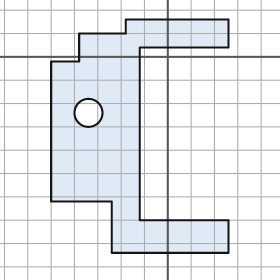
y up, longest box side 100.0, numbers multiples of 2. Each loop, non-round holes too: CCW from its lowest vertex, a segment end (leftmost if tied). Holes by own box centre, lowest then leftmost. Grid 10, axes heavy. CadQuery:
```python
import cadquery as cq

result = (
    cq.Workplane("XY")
    .moveTo(-24.0, -84.0)
    .lineTo(26.0, -84.0)
    .lineTo(26.0, -70.0)
    .lineTo(-12.0, -70.0)
    .lineTo(-12.0, 4.0)
    .lineTo(26.0, 4.0)
    .lineTo(26.0, 16.0)
    .lineTo(-18.0, 16.0)
    .lineTo(-18.0, 10.0)
    .lineTo(-38.0, 10.0)
    .lineTo(-38.0, -2.0)
    .lineTo(-50.0, -2.0)
    .lineTo(-50.0, -62.0)
    .lineTo(-24.0, -62.0)
    .close()
    .moveTo(-34.0, -24.0)
    .circle(6.0)
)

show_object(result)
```